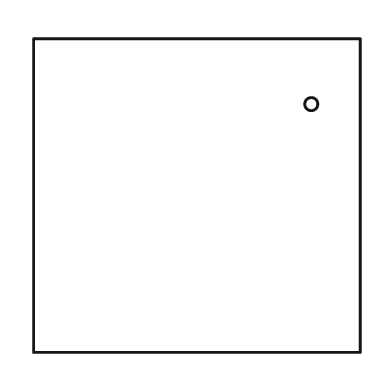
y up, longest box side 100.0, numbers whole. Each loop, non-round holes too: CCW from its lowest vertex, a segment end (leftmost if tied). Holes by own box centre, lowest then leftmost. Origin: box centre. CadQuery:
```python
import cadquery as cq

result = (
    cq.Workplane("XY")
    .moveTo(-50.0, -48.0)
    .lineTo(50.0, -48.0)
    .lineTo(50.0, 48.0)
    .lineTo(-50.0, 48.0)
    .close()
    .moveTo(35.0, 28.0)
    .circle(2.0)
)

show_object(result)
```